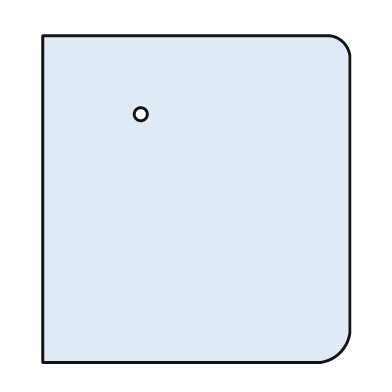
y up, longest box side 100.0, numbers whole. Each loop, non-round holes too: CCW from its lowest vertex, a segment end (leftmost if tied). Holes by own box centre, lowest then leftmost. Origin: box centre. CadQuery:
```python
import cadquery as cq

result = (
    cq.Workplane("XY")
    .moveTo(-47.0, -50.0)
    .lineTo(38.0, -50.0)
    .threePointArc((44.0, -47.0), (47.0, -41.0))
    .lineTo(47.0, 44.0)
    .threePointArc((45.0, 48.0), (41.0, 50.0))
    .lineTo(-47.0, 50.0)
    .close()
    .moveTo(-17.0, 26.0)
    .circle(2.0)
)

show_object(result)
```